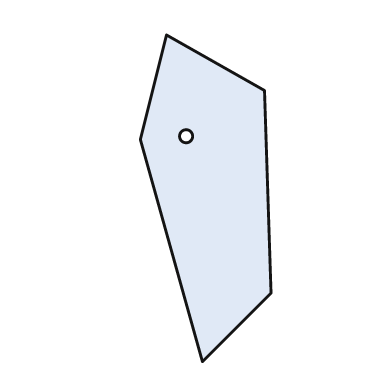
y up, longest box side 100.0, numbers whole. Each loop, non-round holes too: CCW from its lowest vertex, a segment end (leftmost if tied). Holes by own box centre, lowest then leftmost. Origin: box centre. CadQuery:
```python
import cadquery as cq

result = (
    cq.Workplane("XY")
    .moveTo(-1.0, -50.0)
    .lineTo(20.0, -29.0)
    .lineTo(18.0, 33.0)
    .lineTo(-12.0, 50.0)
    .lineTo(-20.0, 18.0)
    .close()
    .moveTo(-6.0, 19.0)
    .circle(2.0)
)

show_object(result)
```